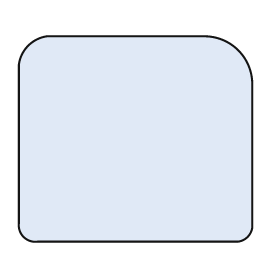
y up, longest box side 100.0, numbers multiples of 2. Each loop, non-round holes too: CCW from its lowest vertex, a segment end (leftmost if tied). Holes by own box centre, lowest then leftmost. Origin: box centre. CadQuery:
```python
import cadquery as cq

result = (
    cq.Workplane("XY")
    .moveTo(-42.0, -44.0)
    .lineTo(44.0, -44.0)
    .threePointArc((48.0, -42.0), (50.0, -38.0))
    .lineTo(50.0, 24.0)
    .threePointArc((44.0, 38.0), (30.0, 44.0))
    .lineTo(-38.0, 44.0)
    .threePointArc((-46.0, 40.0), (-50.0, 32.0))
    .lineTo(-50.0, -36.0)
    .threePointArc((-48.0, -42.0), (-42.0, -44.0))
    .close()
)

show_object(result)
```